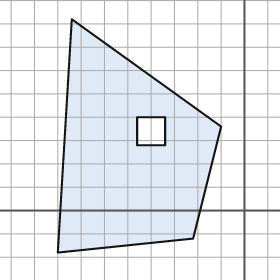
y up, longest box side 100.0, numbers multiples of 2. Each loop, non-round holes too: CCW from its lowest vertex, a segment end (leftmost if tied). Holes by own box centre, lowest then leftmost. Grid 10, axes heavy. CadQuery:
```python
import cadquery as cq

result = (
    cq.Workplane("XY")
    .moveTo(-80.0, -18.0)
    .lineTo(-22.0, -12.0)
    .lineTo(-10.0, 36.0)
    .lineTo(-74.0, 82.0)
    .close()
    .moveTo(-46.0, 28.0)
    .lineTo(-34.0, 28.0)
    .lineTo(-34.0, 40.0)
    .lineTo(-46.0, 40.0)
    .close()
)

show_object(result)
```